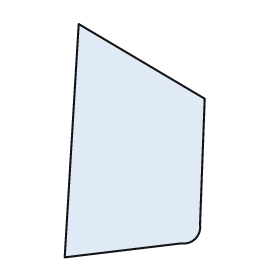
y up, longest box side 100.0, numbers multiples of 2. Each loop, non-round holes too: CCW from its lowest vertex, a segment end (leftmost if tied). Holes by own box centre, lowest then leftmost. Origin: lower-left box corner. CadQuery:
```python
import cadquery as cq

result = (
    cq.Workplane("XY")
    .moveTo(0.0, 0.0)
    .lineTo(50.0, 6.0)
    .threePointArc((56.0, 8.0), (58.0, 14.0))
    .lineTo(60.0, 68.0)
    .lineTo(6.0, 100.0)
    .close()
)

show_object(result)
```